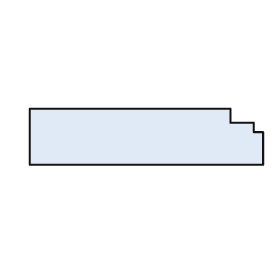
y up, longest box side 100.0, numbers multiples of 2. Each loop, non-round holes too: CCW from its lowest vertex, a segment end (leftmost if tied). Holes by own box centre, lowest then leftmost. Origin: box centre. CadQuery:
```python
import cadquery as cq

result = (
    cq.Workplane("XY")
    .moveTo(-50.0, -12.0)
    .lineTo(50.0, -12.0)
    .lineTo(50.0, 2.0)
    .lineTo(46.0, 2.0)
    .lineTo(46.0, 6.0)
    .lineTo(36.0, 6.0)
    .lineTo(36.0, 12.0)
    .lineTo(-50.0, 12.0)
    .close()
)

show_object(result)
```